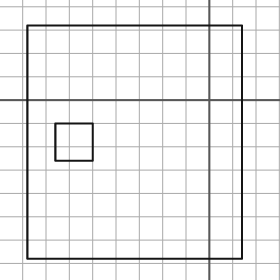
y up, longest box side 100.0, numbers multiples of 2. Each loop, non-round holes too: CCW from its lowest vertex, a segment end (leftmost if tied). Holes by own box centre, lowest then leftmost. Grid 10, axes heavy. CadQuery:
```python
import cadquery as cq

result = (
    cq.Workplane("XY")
    .moveTo(-78.0, -68.0)
    .lineTo(14.0, -68.0)
    .lineTo(14.0, 32.0)
    .lineTo(-78.0, 32.0)
    .close()
    .moveTo(-66.0, -26.0)
    .lineTo(-50.0, -26.0)
    .lineTo(-50.0, -10.0)
    .lineTo(-66.0, -10.0)
    .close()
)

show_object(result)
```